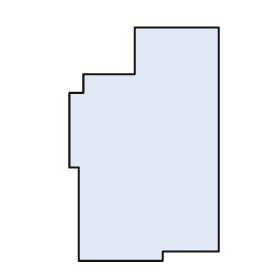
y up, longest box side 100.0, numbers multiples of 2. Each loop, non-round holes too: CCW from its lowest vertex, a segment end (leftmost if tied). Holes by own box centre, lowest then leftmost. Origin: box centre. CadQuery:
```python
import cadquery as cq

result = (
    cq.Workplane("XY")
    .moveTo(-28.0, -50.0)
    .lineTo(8.0, -50.0)
    .lineTo(8.0, -46.0)
    .lineTo(32.0, -46.0)
    .lineTo(32.0, 50.0)
    .lineTo(-4.0, 50.0)
    .lineTo(-4.0, 30.0)
    .lineTo(-26.0, 30.0)
    .lineTo(-26.0, 22.0)
    .lineTo(-32.0, 22.0)
    .lineTo(-32.0, -10.0)
    .lineTo(-28.0, -10.0)
    .close()
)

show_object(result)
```